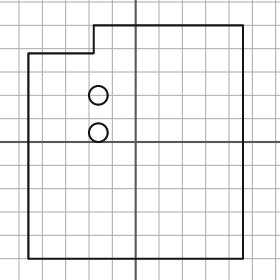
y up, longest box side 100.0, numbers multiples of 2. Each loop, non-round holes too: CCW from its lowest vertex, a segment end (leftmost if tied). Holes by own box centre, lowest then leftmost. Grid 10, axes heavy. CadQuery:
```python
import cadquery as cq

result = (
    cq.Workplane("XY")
    .moveTo(-46.0, -50.0)
    .lineTo(46.0, -50.0)
    .lineTo(46.0, 50.0)
    .lineTo(-18.0, 50.0)
    .lineTo(-18.0, 38.0)
    .lineTo(-46.0, 38.0)
    .close()
    .moveTo(-16.0, 4.0)
    .circle(4.0)
    .moveTo(-16.0, 20.0)
    .circle(4.0)
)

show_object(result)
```